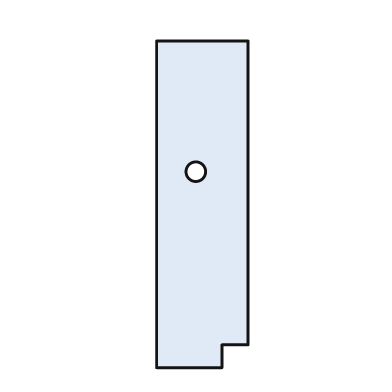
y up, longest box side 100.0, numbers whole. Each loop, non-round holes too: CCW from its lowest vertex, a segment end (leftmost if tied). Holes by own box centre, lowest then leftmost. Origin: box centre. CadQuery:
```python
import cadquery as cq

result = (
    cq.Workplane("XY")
    .moveTo(-14.0, -50.0)
    .lineTo(6.0, -50.0)
    .lineTo(6.0, -43.0)
    .lineTo(14.0, -43.0)
    .lineTo(14.0, 50.0)
    .lineTo(-14.0, 50.0)
    .close()
    .moveTo(-2.0, 10.0)
    .circle(3.0)
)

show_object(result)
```